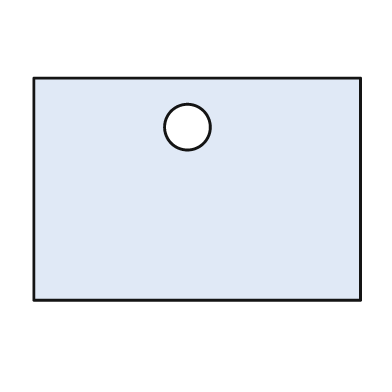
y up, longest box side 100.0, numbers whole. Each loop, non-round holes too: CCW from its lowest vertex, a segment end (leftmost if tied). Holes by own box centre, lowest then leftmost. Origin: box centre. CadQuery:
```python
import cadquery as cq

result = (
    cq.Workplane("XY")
    .moveTo(-50.0, -34.0)
    .lineTo(50.0, -34.0)
    .lineTo(50.0, 34.0)
    .lineTo(-50.0, 34.0)
    .close()
    .moveTo(-3.0, 19.0)
    .circle(7.0)
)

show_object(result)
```